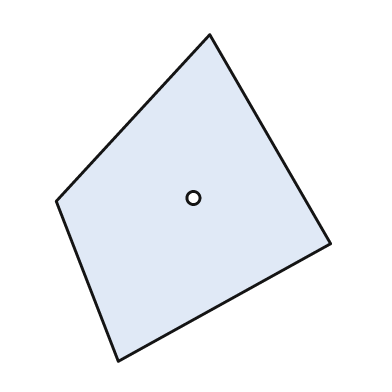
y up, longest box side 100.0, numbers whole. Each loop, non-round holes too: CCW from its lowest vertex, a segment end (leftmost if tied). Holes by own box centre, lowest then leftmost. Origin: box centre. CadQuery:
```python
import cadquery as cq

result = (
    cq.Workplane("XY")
    .moveTo(-23.0, -50.0)
    .lineTo(42.0, -14.0)
    .lineTo(5.0, 50.0)
    .lineTo(-42.0, -1.0)
    .close()
    .moveTo(0.0, 0.0)
    .circle(2.0)
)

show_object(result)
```